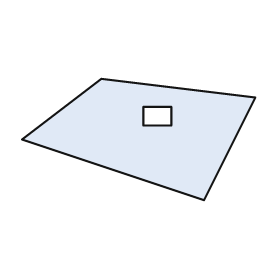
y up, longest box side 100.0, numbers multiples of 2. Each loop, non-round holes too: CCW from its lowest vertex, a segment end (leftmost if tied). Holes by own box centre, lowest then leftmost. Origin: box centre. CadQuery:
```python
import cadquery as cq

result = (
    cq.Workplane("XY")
    .moveTo(28.0, -26.0)
    .lineTo(50.0, 18.0)
    .lineTo(-16.0, 26.0)
    .lineTo(-50.0, 0.0)
    .close()
    .moveTo(2.0, 6.0)
    .lineTo(14.0, 6.0)
    .lineTo(14.0, 14.0)
    .lineTo(2.0, 14.0)
    .close()
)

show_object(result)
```